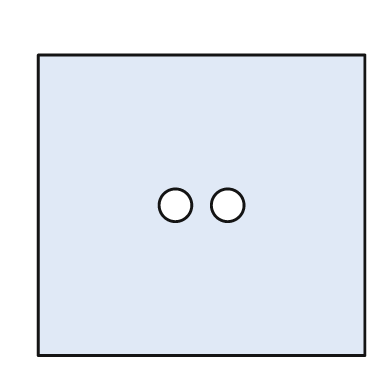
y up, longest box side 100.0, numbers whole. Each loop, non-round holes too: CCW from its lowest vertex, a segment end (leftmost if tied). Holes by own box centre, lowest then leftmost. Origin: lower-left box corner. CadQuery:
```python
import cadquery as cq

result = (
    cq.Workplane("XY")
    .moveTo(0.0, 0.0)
    .lineTo(100.0, 0.0)
    .lineTo(100.0, 92.0)
    .lineTo(0.0, 92.0)
    .close()
    .moveTo(42.0, 46.0)
    .circle(5.0)
    .moveTo(58.0, 46.0)
    .circle(5.0)
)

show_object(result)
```